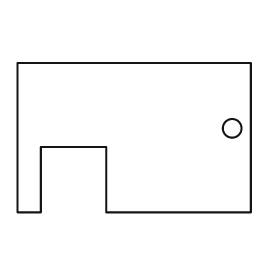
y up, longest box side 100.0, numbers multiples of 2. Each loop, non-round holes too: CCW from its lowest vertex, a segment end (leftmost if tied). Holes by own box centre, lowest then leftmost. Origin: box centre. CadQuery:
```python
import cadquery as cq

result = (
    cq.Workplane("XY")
    .moveTo(-50.0, -32.0)
    .lineTo(-40.0, -32.0)
    .lineTo(-40.0, -4.0)
    .lineTo(-12.0, -4.0)
    .lineTo(-12.0, -32.0)
    .lineTo(50.0, -32.0)
    .lineTo(50.0, 32.0)
    .lineTo(-50.0, 32.0)
    .close()
    .moveTo(42.0, 4.0)
    .circle(4.0)
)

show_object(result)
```